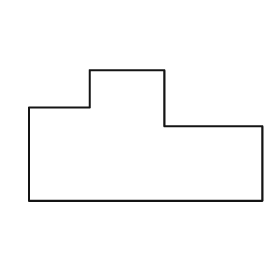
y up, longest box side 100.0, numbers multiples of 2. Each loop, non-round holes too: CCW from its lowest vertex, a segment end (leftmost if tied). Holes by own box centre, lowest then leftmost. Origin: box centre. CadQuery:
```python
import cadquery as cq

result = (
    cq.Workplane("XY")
    .moveTo(-50.0, -28.0)
    .lineTo(50.0, -28.0)
    .lineTo(50.0, 4.0)
    .lineTo(8.0, 4.0)
    .lineTo(8.0, 28.0)
    .lineTo(-24.0, 28.0)
    .lineTo(-24.0, 12.0)
    .lineTo(-50.0, 12.0)
    .close()
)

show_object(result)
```